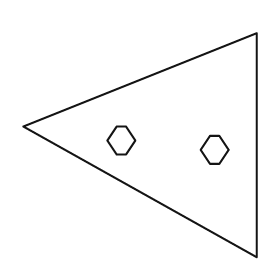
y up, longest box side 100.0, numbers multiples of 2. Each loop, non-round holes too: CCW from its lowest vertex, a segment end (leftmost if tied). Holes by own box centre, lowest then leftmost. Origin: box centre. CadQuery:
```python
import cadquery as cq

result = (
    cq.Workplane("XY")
    .moveTo(50.0, -48.0)
    .lineTo(50.0, 48.0)
    .lineTo(-50.0, 8.0)
    .close()
    .moveTo(30.0, -8.0)
    .lineTo(34.0, -8.0)
    .lineTo(38.0, -2.0)
    .lineTo(34.0, 4.0)
    .lineTo(30.0, 4.0)
    .lineTo(26.0, -2.0)
    .close()
    .moveTo(-10.0, -4.0)
    .lineTo(-6.0, -4.0)
    .lineTo(-2.0, 2.0)
    .lineTo(-6.0, 8.0)
    .lineTo(-10.0, 8.0)
    .lineTo(-14.0, 2.0)
    .close()
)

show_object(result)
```